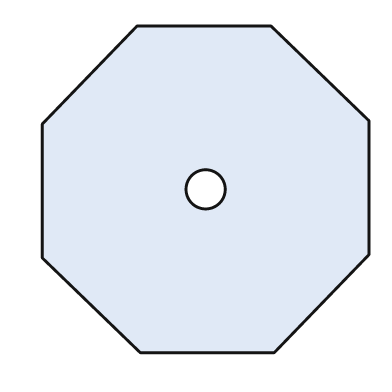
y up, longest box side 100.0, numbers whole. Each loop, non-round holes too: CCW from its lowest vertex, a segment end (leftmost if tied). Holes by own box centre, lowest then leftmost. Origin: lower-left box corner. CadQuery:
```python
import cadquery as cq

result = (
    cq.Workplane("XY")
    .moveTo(30.0, 0.0)
    .lineTo(71.0, 0.0)
    .lineTo(100.0, 30.0)
    .lineTo(100.0, 71.0)
    .lineTo(70.0, 100.0)
    .lineTo(29.0, 100.0)
    .lineTo(0.0, 70.0)
    .lineTo(0.0, 29.0)
    .close()
    .moveTo(50.0, 50.0)
    .circle(6.0)
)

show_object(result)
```